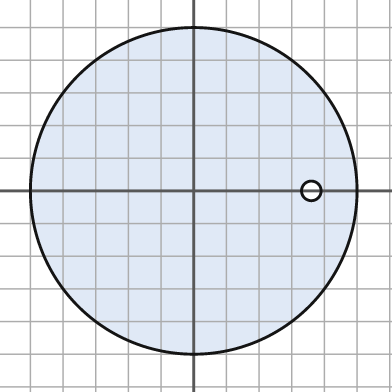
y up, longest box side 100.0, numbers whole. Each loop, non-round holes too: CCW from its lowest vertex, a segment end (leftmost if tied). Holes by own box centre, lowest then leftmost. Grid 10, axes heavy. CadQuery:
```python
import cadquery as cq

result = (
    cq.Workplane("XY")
    .moveTo(0.0, 0.0)
    .circle(50.0)
    .moveTo(36.0, 0.0)
    .circle(3.0)
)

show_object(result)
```